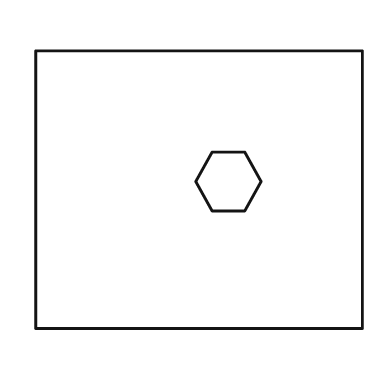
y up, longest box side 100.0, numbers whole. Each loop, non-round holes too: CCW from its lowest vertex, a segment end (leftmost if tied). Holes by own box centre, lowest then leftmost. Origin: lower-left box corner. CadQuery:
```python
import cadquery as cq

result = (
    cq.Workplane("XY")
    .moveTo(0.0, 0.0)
    .lineTo(100.0, 0.0)
    .lineTo(100.0, 85.0)
    .lineTo(0.0, 85.0)
    .close()
    .moveTo(54.0, 36.0)
    .lineTo(64.0, 36.0)
    .lineTo(69.0, 45.0)
    .lineTo(64.0, 54.0)
    .lineTo(54.0, 54.0)
    .lineTo(49.0, 45.0)
    .close()
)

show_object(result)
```